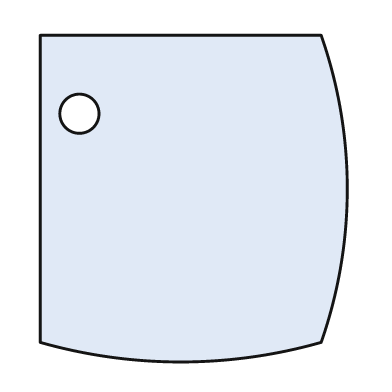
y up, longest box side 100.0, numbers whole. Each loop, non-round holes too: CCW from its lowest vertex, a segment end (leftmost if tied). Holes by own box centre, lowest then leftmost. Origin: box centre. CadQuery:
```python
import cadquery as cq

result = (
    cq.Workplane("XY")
    .moveTo(-47.0, -44.0)
    .threePointArc((-4.0, -50.0), (39.0, -44.0))
    .threePointArc((47.0, 3.0), (39.0, 50.0))
    .lineTo(-47.0, 50.0)
    .close()
    .moveTo(-35.0, 26.0)
    .circle(6.0)
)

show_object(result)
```